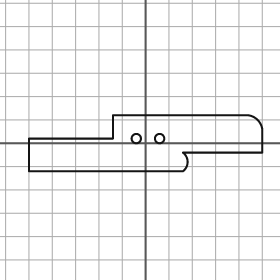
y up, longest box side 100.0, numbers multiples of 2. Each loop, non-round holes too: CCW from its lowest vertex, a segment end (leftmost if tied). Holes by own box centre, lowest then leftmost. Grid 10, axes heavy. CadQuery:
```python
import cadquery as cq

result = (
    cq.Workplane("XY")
    .moveTo(-50.0, -12.0)
    .lineTo(16.0, -12.0)
    .threePointArc((18.0, -8.0), (16.0, -4.0))
    .lineTo(50.0, -4.0)
    .lineTo(50.0, 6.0)
    .threePointArc((48.0, 10.0), (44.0, 12.0))
    .lineTo(-14.0, 12.0)
    .lineTo(-14.0, 2.0)
    .lineTo(-50.0, 2.0)
    .close()
    .moveTo(-4.0, 2.0)
    .circle(2.0)
    .moveTo(6.0, 2.0)
    .circle(2.0)
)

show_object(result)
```